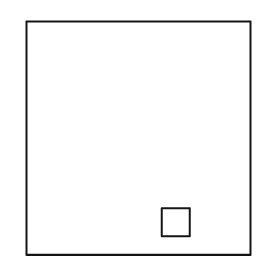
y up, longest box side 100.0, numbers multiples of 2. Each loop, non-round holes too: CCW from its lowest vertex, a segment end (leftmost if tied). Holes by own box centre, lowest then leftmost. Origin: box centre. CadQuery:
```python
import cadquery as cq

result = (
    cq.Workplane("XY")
    .moveTo(-48.0, -50.0)
    .lineTo(48.0, -50.0)
    .lineTo(48.0, 50.0)
    .lineTo(-48.0, 50.0)
    .close()
    .moveTo(10.0, -42.0)
    .lineTo(22.0, -42.0)
    .lineTo(22.0, -30.0)
    .lineTo(10.0, -30.0)
    .close()
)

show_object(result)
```